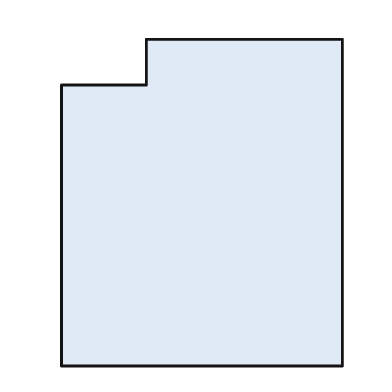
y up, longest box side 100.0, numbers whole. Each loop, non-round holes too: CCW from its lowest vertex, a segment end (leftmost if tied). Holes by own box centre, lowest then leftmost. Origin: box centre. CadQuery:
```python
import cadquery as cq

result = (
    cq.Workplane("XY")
    .moveTo(-43.0, -50.0)
    .lineTo(43.0, -50.0)
    .lineTo(43.0, 50.0)
    .lineTo(-17.0, 50.0)
    .lineTo(-17.0, 36.0)
    .lineTo(-43.0, 36.0)
    .close()
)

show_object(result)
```